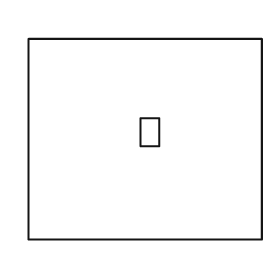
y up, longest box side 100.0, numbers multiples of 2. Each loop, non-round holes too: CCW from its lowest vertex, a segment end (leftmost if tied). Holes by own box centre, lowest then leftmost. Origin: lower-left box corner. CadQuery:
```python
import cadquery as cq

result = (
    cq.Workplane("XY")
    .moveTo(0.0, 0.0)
    .lineTo(100.0, 0.0)
    .lineTo(100.0, 86.0)
    .lineTo(0.0, 86.0)
    .close()
    .moveTo(48.0, 40.0)
    .lineTo(56.0, 40.0)
    .lineTo(56.0, 52.0)
    .lineTo(48.0, 52.0)
    .close()
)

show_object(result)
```